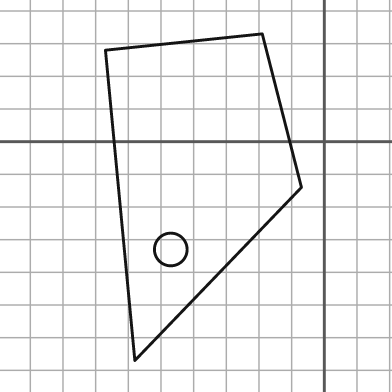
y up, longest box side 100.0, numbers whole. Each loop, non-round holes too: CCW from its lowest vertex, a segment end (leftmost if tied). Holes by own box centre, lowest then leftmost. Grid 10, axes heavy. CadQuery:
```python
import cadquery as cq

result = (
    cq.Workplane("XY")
    .moveTo(-58.0, -67.0)
    .lineTo(-7.0, -14.0)
    .lineTo(-19.0, 33.0)
    .lineTo(-67.0, 28.0)
    .close()
    .moveTo(-47.0, -33.0)
    .circle(5.0)
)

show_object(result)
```